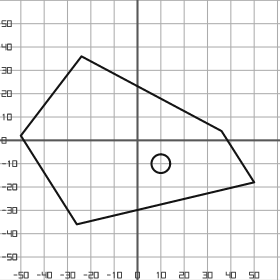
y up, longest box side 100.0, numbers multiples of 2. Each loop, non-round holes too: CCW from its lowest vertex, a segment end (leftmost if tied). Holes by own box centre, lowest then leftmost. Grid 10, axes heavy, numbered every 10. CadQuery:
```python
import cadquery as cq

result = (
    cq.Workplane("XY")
    .moveTo(-26.0, -36.0)
    .lineTo(50.0, -18.0)
    .lineTo(36.0, 4.0)
    .lineTo(-24.0, 36.0)
    .lineTo(-50.0, 2.0)
    .close()
    .moveTo(10.0, -10.0)
    .circle(4.0)
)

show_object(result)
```